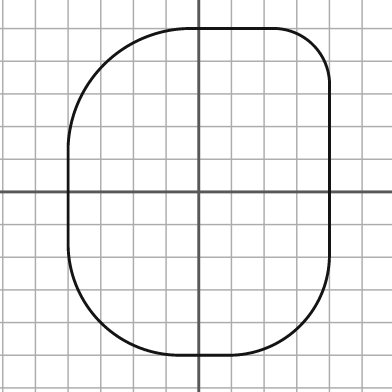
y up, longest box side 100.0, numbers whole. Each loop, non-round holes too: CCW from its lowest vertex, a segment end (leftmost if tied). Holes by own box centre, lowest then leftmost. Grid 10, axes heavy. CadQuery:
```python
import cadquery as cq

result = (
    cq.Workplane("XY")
    .moveTo(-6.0, -50.0)
    .lineTo(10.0, -50.0)
    .threePointArc((31.0, -41.0), (40.0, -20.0))
    .lineTo(40.0, 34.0)
    .threePointArc((35.0, 45.0), (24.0, 50.0))
    .lineTo(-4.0, 50.0)
    .threePointArc((-29.0, 39.0), (-40.0, 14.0))
    .lineTo(-40.0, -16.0)
    .threePointArc((-30.0, -40.0), (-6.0, -50.0))
    .close()
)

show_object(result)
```